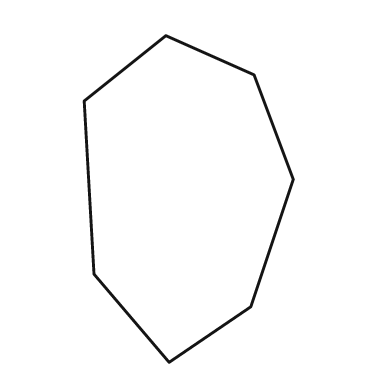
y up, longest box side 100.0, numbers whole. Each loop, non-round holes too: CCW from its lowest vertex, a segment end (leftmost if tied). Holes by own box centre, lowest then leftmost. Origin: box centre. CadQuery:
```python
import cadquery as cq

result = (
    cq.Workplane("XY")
    .moveTo(-6.0, -50.0)
    .lineTo(19.0, -33.0)
    .lineTo(32.0, 6.0)
    .lineTo(20.0, 38.0)
    .lineTo(-7.0, 50.0)
    .lineTo(-32.0, 30.0)
    .lineTo(-29.0, -23.0)
    .close()
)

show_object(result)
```